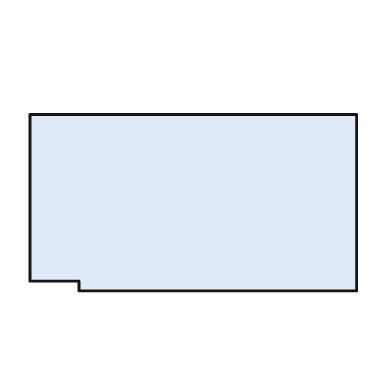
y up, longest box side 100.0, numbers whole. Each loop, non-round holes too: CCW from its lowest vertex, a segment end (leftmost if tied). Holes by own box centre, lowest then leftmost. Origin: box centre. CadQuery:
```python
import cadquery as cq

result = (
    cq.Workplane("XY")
    .moveTo(-35.0, -27.0)
    .lineTo(50.0, -27.0)
    .lineTo(50.0, 27.0)
    .lineTo(-50.0, 27.0)
    .lineTo(-50.0, -24.0)
    .lineTo(-35.0, -24.0)
    .close()
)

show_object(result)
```